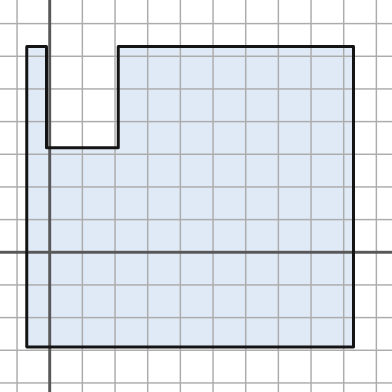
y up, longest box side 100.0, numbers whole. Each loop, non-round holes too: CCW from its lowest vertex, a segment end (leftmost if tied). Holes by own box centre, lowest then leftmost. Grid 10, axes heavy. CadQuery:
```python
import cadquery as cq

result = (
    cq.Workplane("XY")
    .moveTo(-7.0, -29.0)
    .lineTo(93.0, -29.0)
    .lineTo(93.0, 63.0)
    .lineTo(21.0, 63.0)
    .lineTo(21.0, 32.0)
    .lineTo(-1.0, 32.0)
    .lineTo(-1.0, 63.0)
    .lineTo(-7.0, 63.0)
    .close()
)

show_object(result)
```